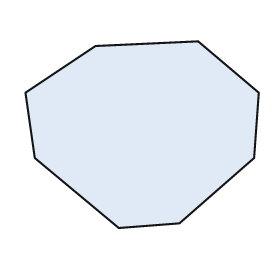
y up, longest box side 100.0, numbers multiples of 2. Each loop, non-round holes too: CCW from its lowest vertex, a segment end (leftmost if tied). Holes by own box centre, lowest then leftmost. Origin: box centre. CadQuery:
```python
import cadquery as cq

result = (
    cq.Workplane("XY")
    .moveTo(-10.0, -40.0)
    .lineTo(16.0, -38.0)
    .lineTo(48.0, -10.0)
    .lineTo(50.0, 18.0)
    .lineTo(24.0, 40.0)
    .lineTo(-20.0, 38.0)
    .lineTo(-50.0, 18.0)
    .lineTo(-46.0, -10.0)
    .close()
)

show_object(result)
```